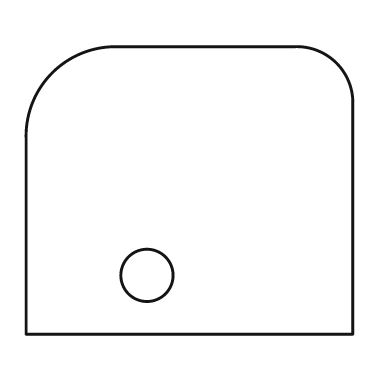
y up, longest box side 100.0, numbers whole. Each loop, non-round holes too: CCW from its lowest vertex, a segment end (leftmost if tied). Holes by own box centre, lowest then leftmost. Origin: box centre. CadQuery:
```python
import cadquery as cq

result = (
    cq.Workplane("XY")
    .moveTo(-50.0, -44.0)
    .lineTo(50.0, -44.0)
    .lineTo(50.0, 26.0)
    .threePointArc((45.0, 39.0), (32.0, 44.0))
    .lineTo(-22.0, 44.0)
    .threePointArc((-42.0, 36.0), (-50.0, 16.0))
    .close()
    .moveTo(-13.0, -26.0)
    .circle(8.0)
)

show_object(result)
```